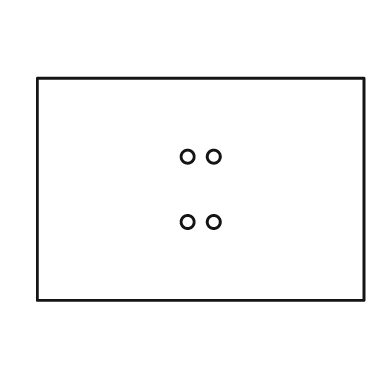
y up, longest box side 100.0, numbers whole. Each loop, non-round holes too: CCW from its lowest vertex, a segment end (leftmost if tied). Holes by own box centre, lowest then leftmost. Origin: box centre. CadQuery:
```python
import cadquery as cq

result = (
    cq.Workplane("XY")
    .moveTo(-50.0, -34.0)
    .lineTo(50.0, -34.0)
    .lineTo(50.0, 34.0)
    .lineTo(-50.0, 34.0)
    .close()
    .moveTo(-4.0, -10.0)
    .circle(2.0)
    .moveTo(4.0, -10.0)
    .circle(2.0)
    .moveTo(-4.0, 10.0)
    .circle(2.0)
    .moveTo(4.0, 10.0)
    .circle(2.0)
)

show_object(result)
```